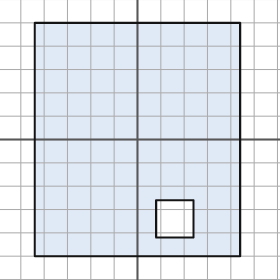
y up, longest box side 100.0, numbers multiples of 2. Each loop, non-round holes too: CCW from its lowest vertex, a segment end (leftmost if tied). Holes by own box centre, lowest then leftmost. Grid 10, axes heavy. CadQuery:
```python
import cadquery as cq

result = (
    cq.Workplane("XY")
    .moveTo(-44.0, -50.0)
    .lineTo(44.0, -50.0)
    .lineTo(44.0, 50.0)
    .lineTo(-44.0, 50.0)
    .close()
    .moveTo(8.0, -42.0)
    .lineTo(24.0, -42.0)
    .lineTo(24.0, -26.0)
    .lineTo(8.0, -26.0)
    .close()
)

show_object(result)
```